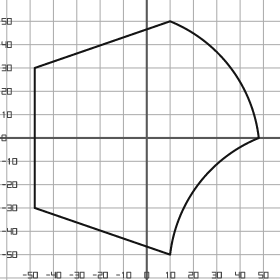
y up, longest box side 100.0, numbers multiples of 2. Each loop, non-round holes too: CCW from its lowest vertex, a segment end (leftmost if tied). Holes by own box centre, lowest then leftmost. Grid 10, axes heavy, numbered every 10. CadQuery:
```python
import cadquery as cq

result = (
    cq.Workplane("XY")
    .moveTo(10.0, -50.0)
    .threePointArc((22.0, -20.0), (48.0, 0.0))
    .threePointArc((36.0, 30.0), (10.0, 50.0))
    .lineTo(-48.0, 30.0)
    .lineTo(-48.0, -30.0)
    .close()
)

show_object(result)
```